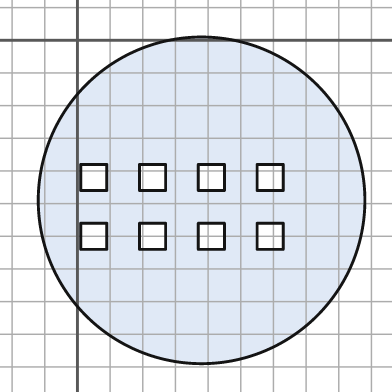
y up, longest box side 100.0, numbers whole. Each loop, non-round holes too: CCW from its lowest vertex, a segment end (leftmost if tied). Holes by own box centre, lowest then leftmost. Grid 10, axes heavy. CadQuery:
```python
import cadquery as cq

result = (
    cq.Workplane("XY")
    .moveTo(38.0, -49.0)
    .circle(50.0)
    .moveTo(1.0, -64.0)
    .lineTo(9.0, -64.0)
    .lineTo(9.0, -56.0)
    .lineTo(1.0, -56.0)
    .close()
    .moveTo(19.0, -64.0)
    .lineTo(27.0, -64.0)
    .lineTo(27.0, -56.0)
    .lineTo(19.0, -56.0)
    .close()
    .moveTo(37.0, -64.0)
    .lineTo(45.0, -64.0)
    .lineTo(45.0, -56.0)
    .lineTo(37.0, -56.0)
    .close()
    .moveTo(55.0, -64.0)
    .lineTo(63.0, -64.0)
    .lineTo(63.0, -56.0)
    .lineTo(55.0, -56.0)
    .close()
    .moveTo(1.0, -46.0)
    .lineTo(9.0, -46.0)
    .lineTo(9.0, -38.0)
    .lineTo(1.0, -38.0)
    .close()
    .moveTo(19.0, -46.0)
    .lineTo(27.0, -46.0)
    .lineTo(27.0, -38.0)
    .lineTo(19.0, -38.0)
    .close()
    .moveTo(37.0, -46.0)
    .lineTo(45.0, -46.0)
    .lineTo(45.0, -38.0)
    .lineTo(37.0, -38.0)
    .close()
    .moveTo(55.0, -46.0)
    .lineTo(63.0, -46.0)
    .lineTo(63.0, -38.0)
    .lineTo(55.0, -38.0)
    .close()
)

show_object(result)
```